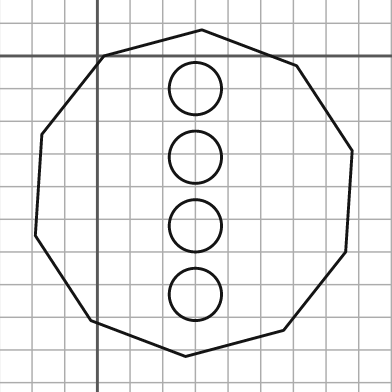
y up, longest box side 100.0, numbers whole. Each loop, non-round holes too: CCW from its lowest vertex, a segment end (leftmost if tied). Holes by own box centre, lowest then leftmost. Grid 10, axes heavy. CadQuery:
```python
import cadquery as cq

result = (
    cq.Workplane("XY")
    .moveTo(27.0, -92.0)
    .lineTo(57.0, -84.0)
    .lineTo(76.0, -60.0)
    .lineTo(78.0, -29.0)
    .lineTo(61.0, -3.0)
    .lineTo(32.0, 8.0)
    .lineTo(2.0, 0.0)
    .lineTo(-17.0, -24.0)
    .lineTo(-19.0, -55.0)
    .lineTo(-2.0, -81.0)
    .close()
    .moveTo(30.0, -73.0)
    .circle(8.0)
    .moveTo(30.0, -52.0)
    .circle(8.0)
    .moveTo(30.0, -31.0)
    .circle(8.0)
    .moveTo(30.0, -10.0)
    .circle(8.0)
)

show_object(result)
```